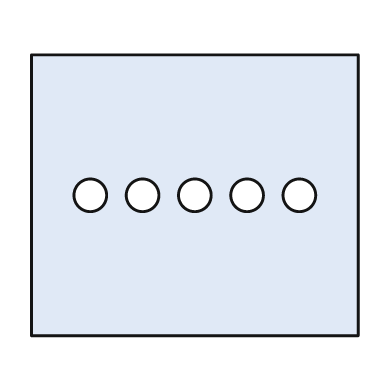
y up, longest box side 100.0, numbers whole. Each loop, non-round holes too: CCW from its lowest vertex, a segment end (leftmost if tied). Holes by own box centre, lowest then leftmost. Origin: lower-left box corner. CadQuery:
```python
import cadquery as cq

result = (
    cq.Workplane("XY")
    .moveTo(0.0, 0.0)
    .lineTo(100.0, 0.0)
    .lineTo(100.0, 86.0)
    .lineTo(0.0, 86.0)
    .close()
    .moveTo(18.0, 43.0)
    .circle(5.0)
    .moveTo(34.0, 43.0)
    .circle(5.0)
    .moveTo(50.0, 43.0)
    .circle(5.0)
    .moveTo(66.0, 43.0)
    .circle(5.0)
    .moveTo(82.0, 43.0)
    .circle(5.0)
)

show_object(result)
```